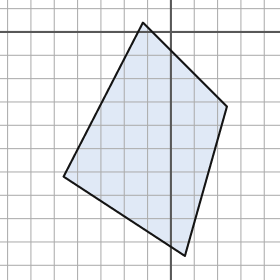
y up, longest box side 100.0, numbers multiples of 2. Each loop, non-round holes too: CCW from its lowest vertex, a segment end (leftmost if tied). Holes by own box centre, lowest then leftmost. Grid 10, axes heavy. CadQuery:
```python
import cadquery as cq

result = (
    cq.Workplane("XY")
    .moveTo(6.0, -96.0)
    .lineTo(24.0, -32.0)
    .lineTo(-12.0, 4.0)
    .lineTo(-46.0, -62.0)
    .close()
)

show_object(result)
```